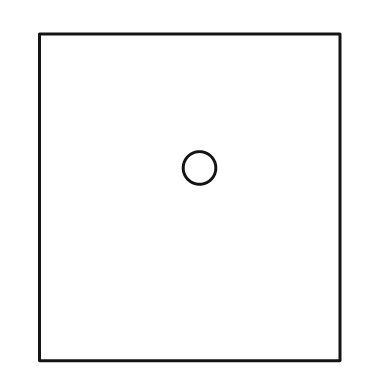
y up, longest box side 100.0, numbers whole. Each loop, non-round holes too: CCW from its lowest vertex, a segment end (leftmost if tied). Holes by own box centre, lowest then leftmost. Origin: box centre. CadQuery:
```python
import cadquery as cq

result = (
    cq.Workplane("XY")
    .moveTo(-46.0, -50.0)
    .lineTo(46.0, -50.0)
    .lineTo(46.0, 50.0)
    .lineTo(-46.0, 50.0)
    .close()
    .moveTo(3.0, 9.0)
    .circle(5.0)
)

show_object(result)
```